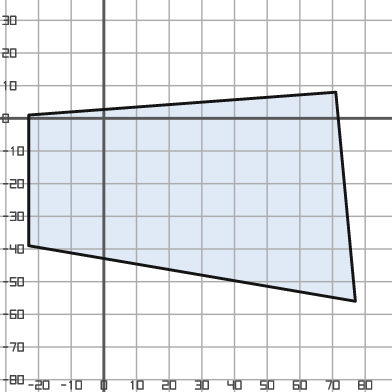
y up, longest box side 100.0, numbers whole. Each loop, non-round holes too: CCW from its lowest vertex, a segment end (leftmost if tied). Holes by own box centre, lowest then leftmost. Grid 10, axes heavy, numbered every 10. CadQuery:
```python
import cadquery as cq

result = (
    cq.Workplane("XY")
    .moveTo(77.0, -56.0)
    .lineTo(71.0, 8.0)
    .lineTo(-23.0, 1.0)
    .lineTo(-23.0, -39.0)
    .close()
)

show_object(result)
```